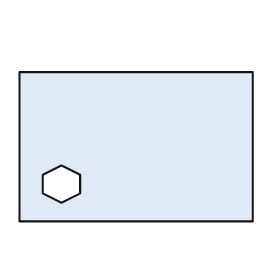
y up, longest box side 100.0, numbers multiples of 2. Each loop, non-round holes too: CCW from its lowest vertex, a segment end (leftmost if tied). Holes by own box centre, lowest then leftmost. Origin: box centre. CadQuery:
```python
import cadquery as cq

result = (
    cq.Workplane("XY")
    .moveTo(-50.0, -32.0)
    .lineTo(50.0, -32.0)
    .lineTo(50.0, 32.0)
    .lineTo(-50.0, 32.0)
    .close()
    .moveTo(-32.0, -24.0)
    .lineTo(-24.0, -20.0)
    .lineTo(-24.0, -12.0)
    .lineTo(-32.0, -8.0)
    .lineTo(-40.0, -12.0)
    .lineTo(-40.0, -20.0)
    .close()
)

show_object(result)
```